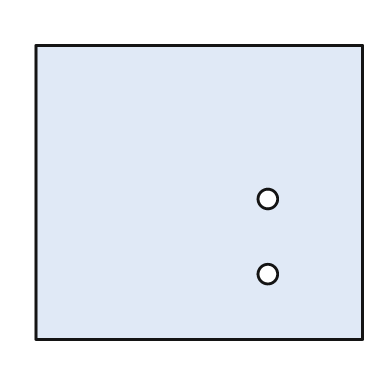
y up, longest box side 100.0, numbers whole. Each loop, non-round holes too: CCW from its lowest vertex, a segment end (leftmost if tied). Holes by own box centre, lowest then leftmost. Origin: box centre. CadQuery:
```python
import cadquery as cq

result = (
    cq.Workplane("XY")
    .moveTo(-50.0, -45.0)
    .lineTo(50.0, -45.0)
    .lineTo(50.0, 45.0)
    .lineTo(-50.0, 45.0)
    .close()
    .moveTo(21.0, -25.0)
    .circle(3.0)
    .moveTo(21.0, -2.0)
    .circle(3.0)
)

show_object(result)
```